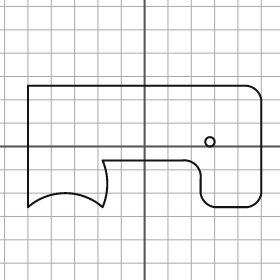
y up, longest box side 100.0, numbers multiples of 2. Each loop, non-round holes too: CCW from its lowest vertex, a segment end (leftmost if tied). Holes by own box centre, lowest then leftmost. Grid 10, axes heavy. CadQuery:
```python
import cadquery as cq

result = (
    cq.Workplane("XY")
    .moveTo(-50.0, -26.0)
    .threePointArc((-34.0, -20.0), (-18.0, -26.0))
    .threePointArc((-16.0, -16.0), (-18.0, -6.0))
    .lineTo(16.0, -6.0)
    .threePointArc((22.0, -8.0), (24.0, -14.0))
    .lineTo(24.0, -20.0)
    .threePointArc((26.0, -24.0), (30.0, -26.0))
    .lineTo(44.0, -26.0)
    .threePointArc((48.0, -24.0), (50.0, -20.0))
    .lineTo(50.0, 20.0)
    .threePointArc((48.0, 24.0), (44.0, 26.0))
    .lineTo(-50.0, 26.0)
    .close()
    .moveTo(28.0, 2.0)
    .circle(2.0)
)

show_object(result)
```